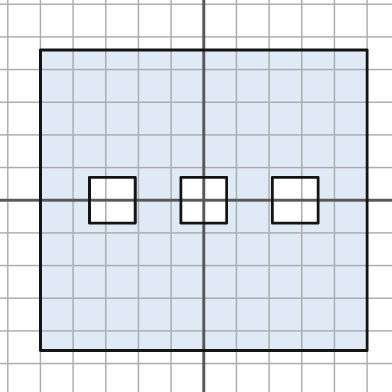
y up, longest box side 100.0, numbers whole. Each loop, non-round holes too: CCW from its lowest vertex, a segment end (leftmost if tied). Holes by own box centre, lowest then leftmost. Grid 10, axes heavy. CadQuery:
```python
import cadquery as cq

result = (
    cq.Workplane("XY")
    .moveTo(-50.0, -46.0)
    .lineTo(50.0, -46.0)
    .lineTo(50.0, 46.0)
    .lineTo(-50.0, 46.0)
    .close()
    .moveTo(-35.0, -7.0)
    .lineTo(-21.0, -7.0)
    .lineTo(-21.0, 7.0)
    .lineTo(-35.0, 7.0)
    .close()
    .moveTo(-7.0, -7.0)
    .lineTo(7.0, -7.0)
    .lineTo(7.0, 7.0)
    .lineTo(-7.0, 7.0)
    .close()
    .moveTo(21.0, -7.0)
    .lineTo(35.0, -7.0)
    .lineTo(35.0, 7.0)
    .lineTo(21.0, 7.0)
    .close()
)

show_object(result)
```